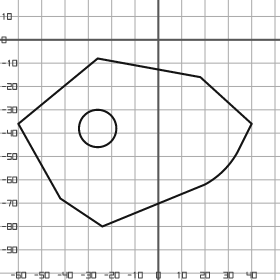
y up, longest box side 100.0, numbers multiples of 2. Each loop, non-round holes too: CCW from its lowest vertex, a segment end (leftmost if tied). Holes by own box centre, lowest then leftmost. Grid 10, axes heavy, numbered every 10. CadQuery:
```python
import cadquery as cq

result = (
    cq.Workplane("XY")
    .moveTo(-24.0, -80.0)
    .lineTo(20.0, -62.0)
    .threePointArc((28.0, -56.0), (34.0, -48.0))
    .lineTo(40.0, -36.0)
    .lineTo(18.0, -16.0)
    .lineTo(-26.0, -8.0)
    .lineTo(-60.0, -36.0)
    .lineTo(-42.0, -68.0)
    .close()
    .moveTo(-26.0, -38.0)
    .circle(8.0)
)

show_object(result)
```